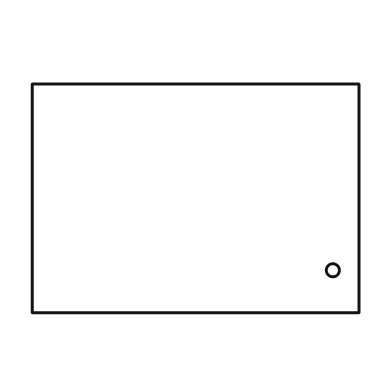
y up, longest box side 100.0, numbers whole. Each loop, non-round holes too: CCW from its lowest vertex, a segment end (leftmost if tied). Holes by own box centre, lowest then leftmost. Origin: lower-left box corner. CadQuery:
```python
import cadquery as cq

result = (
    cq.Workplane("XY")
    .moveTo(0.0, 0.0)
    .lineTo(100.0, 0.0)
    .lineTo(100.0, 70.0)
    .lineTo(0.0, 70.0)
    .close()
    .moveTo(92.0, 13.0)
    .circle(2.0)
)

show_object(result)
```